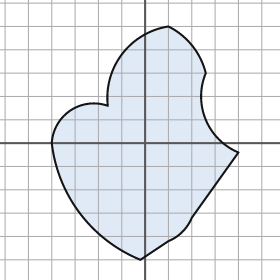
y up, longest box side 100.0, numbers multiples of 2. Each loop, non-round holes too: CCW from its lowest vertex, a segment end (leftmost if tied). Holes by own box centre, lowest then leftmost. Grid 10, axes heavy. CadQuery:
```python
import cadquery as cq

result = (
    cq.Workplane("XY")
    .moveTo(-2.0, -50.0)
    .lineTo(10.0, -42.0)
    .threePointArc((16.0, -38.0), (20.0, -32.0))
    .lineTo(40.0, -4.0)
    .threePointArc((26.0, 10.0), (26.0, 30.0))
    .threePointArc((20.0, 42.0), (10.0, 50.0))
    .threePointArc((-10.0, 38.0), (-16.0, 16.0))
    .threePointArc((-32.0, 14.0), (-40.0, 0.0))
    .threePointArc((-28.0, -30.0), (-2.0, -50.0))
    .close()
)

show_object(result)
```